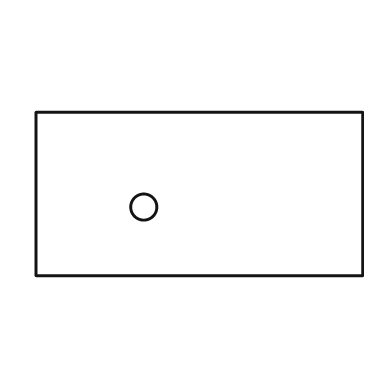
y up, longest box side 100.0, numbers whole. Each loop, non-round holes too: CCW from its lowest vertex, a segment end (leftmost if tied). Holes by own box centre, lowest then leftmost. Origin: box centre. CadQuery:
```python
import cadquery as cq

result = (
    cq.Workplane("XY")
    .moveTo(-50.0, -25.0)
    .lineTo(50.0, -25.0)
    .lineTo(50.0, 25.0)
    .lineTo(-50.0, 25.0)
    .close()
    .moveTo(-17.0, -4.0)
    .circle(4.0)
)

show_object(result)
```